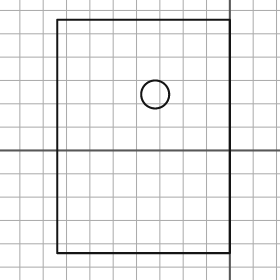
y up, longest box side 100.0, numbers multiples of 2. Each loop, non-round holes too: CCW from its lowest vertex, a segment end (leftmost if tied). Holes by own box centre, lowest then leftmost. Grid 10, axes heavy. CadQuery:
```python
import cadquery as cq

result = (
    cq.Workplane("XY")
    .moveTo(-74.0, -44.0)
    .lineTo(0.0, -44.0)
    .lineTo(0.0, 56.0)
    .lineTo(-74.0, 56.0)
    .close()
    .moveTo(-32.0, 24.0)
    .circle(6.0)
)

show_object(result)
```